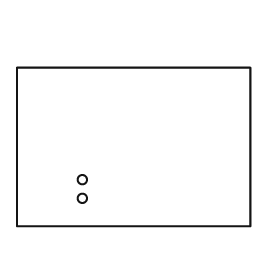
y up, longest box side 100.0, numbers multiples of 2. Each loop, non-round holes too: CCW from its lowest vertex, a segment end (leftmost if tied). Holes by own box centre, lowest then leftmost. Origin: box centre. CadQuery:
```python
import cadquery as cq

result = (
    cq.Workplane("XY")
    .moveTo(-50.0, -34.0)
    .lineTo(50.0, -34.0)
    .lineTo(50.0, 34.0)
    .lineTo(-50.0, 34.0)
    .close()
    .moveTo(-22.0, -22.0)
    .circle(2.0)
    .moveTo(-22.0, -14.0)
    .circle(2.0)
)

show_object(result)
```